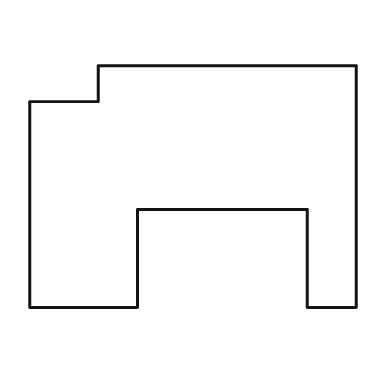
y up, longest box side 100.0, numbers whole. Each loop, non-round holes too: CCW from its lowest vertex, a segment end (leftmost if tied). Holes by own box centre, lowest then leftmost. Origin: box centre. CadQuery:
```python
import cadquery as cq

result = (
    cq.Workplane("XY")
    .moveTo(-50.0, -37.0)
    .lineTo(-17.0, -37.0)
    .lineTo(-17.0, -7.0)
    .lineTo(35.0, -7.0)
    .lineTo(35.0, -37.0)
    .lineTo(50.0, -37.0)
    .lineTo(50.0, 37.0)
    .lineTo(-29.0, 37.0)
    .lineTo(-29.0, 26.0)
    .lineTo(-50.0, 26.0)
    .close()
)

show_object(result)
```